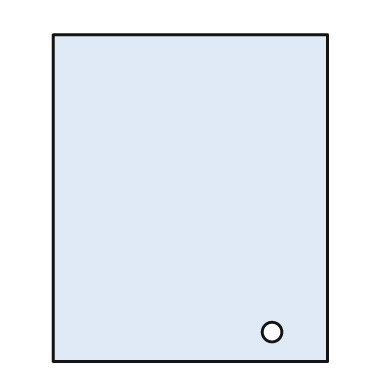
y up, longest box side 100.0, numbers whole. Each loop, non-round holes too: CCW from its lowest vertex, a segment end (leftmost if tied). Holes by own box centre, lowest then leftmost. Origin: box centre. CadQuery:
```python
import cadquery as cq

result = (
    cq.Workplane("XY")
    .moveTo(-42.0, -50.0)
    .lineTo(42.0, -50.0)
    .lineTo(42.0, 50.0)
    .lineTo(-42.0, 50.0)
    .close()
    .moveTo(25.0, -41.0)
    .circle(3.0)
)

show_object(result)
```